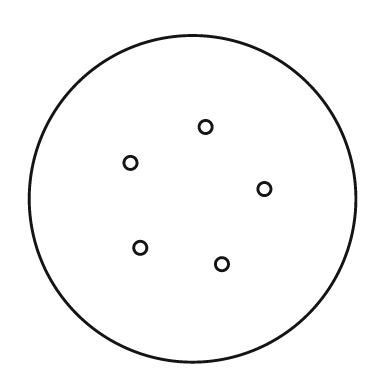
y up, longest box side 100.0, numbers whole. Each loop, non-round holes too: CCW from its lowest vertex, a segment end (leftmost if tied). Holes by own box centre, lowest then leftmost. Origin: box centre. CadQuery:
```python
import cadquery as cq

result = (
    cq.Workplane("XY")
    .moveTo(0.0, 0.0)
    .circle(50.0)
    .moveTo(9.0, -20.0)
    .circle(2.0)
    .moveTo(-16.0, -15.0)
    .circle(2.0)
    .moveTo(22.0, 3.0)
    .circle(2.0)
    .moveTo(-19.0, 11.0)
    .circle(2.0)
    .moveTo(4.0, 22.0)
    .circle(2.0)
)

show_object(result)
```